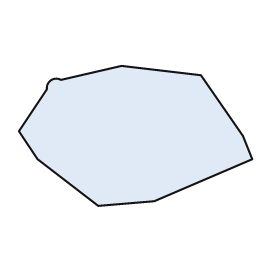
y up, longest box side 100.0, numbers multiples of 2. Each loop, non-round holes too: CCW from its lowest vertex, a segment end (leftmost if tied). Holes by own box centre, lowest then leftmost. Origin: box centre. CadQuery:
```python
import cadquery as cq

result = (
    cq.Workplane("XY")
    .moveTo(-16.0, -30.0)
    .lineTo(8.0, -28.0)
    .lineTo(50.0, -10.0)
    .lineTo(46.0, 0.0)
    .lineTo(28.0, 26.0)
    .lineTo(-6.0, 30.0)
    .lineTo(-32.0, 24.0)
    .threePointArc((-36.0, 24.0), (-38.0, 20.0))
    .lineTo(-50.0, 2.0)
    .lineTo(-42.0, -10.0)
    .close()
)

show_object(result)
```